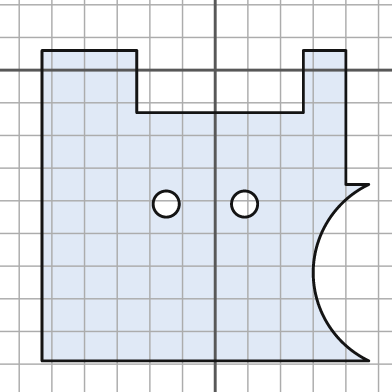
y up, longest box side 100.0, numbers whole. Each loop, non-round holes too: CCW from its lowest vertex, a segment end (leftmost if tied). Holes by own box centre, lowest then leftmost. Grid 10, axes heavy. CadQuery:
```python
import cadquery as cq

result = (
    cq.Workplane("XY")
    .moveTo(-53.0, -89.0)
    .lineTo(47.0, -89.0)
    .threePointArc((30.0, -62.0), (47.0, -35.0))
    .lineTo(40.0, -35.0)
    .lineTo(40.0, 6.0)
    .lineTo(27.0, 6.0)
    .lineTo(27.0, -13.0)
    .lineTo(-24.0, -13.0)
    .lineTo(-24.0, 6.0)
    .lineTo(-53.0, 6.0)
    .close()
    .moveTo(-15.0, -41.0)
    .circle(4.0)
    .moveTo(9.0, -41.0)
    .circle(4.0)
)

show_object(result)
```